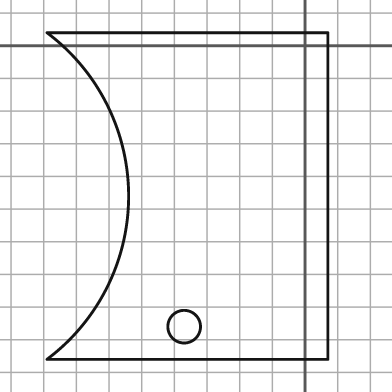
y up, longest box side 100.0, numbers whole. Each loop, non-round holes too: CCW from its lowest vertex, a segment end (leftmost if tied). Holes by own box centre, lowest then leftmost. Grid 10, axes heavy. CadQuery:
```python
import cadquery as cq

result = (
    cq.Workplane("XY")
    .moveTo(-79.0, -96.0)
    .lineTo(7.0, -96.0)
    .lineTo(7.0, 4.0)
    .lineTo(-79.0, 4.0)
    .threePointArc((-54.0, -46.0), (-79.0, -96.0))
    .close()
    .moveTo(-37.0, -86.0)
    .circle(5.0)
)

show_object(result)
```